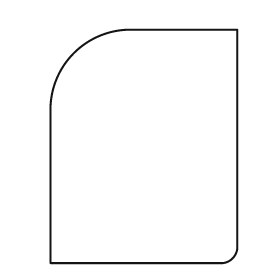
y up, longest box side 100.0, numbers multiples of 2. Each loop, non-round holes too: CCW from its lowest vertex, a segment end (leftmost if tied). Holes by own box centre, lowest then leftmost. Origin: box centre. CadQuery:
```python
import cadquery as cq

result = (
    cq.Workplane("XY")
    .moveTo(-40.0, -50.0)
    .lineTo(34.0, -50.0)
    .threePointArc((38.0, -48.0), (40.0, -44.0))
    .lineTo(40.0, 50.0)
    .lineTo(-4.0, 50.0)
    .threePointArc((-30.0, 40.0), (-40.0, 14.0))
    .close()
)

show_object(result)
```